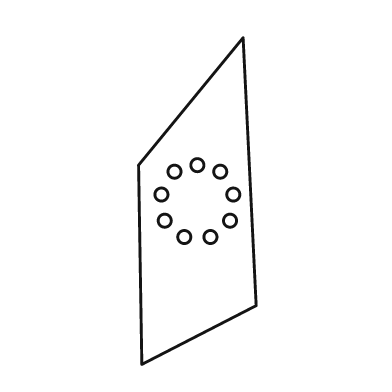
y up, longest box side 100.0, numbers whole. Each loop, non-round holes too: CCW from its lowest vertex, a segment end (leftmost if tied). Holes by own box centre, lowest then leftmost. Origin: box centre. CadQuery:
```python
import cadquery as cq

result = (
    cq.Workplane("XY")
    .moveTo(-17.0, -50.0)
    .lineTo(18.0, -32.0)
    .lineTo(14.0, 50.0)
    .lineTo(-18.0, 11.0)
    .close()
    .moveTo(-4.0, -11.0)
    .circle(2.0)
    .moveTo(4.0, -11.0)
    .circle(2.0)
    .moveTo(-10.0, -6.0)
    .circle(2.0)
    .moveTo(10.0, -6.0)
    .circle(2.0)
    .moveTo(-11.0, 2.0)
    .circle(2.0)
    .moveTo(11.0, 2.0)
    .circle(2.0)
    .moveTo(-7.0, 9.0)
    .circle(2.0)
    .moveTo(7.0, 9.0)
    .circle(2.0)
    .moveTo(0.0, 11.0)
    .circle(2.0)
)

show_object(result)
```